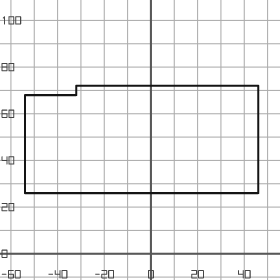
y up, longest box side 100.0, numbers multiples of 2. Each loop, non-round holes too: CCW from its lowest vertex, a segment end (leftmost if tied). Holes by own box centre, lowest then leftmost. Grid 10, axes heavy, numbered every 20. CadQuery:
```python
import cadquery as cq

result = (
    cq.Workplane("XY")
    .moveTo(-54.0, 26.0)
    .lineTo(46.0, 26.0)
    .lineTo(46.0, 72.0)
    .lineTo(-32.0, 72.0)
    .lineTo(-32.0, 68.0)
    .lineTo(-54.0, 68.0)
    .close()
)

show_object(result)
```